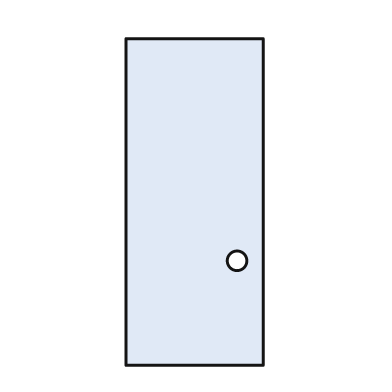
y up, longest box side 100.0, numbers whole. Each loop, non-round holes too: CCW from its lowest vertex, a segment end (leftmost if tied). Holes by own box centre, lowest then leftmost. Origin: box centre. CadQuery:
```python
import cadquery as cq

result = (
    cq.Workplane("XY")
    .moveTo(-21.0, -50.0)
    .lineTo(21.0, -50.0)
    .lineTo(21.0, 50.0)
    .lineTo(-21.0, 50.0)
    .close()
    .moveTo(13.0, -18.0)
    .circle(3.0)
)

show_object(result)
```